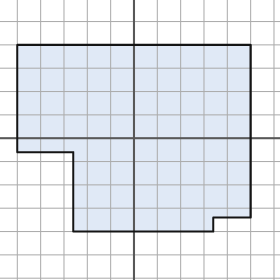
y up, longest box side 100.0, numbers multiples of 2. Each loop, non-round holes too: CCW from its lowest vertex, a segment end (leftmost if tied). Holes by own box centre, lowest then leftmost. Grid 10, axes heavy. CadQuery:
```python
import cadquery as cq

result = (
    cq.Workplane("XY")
    .moveTo(-26.0, -40.0)
    .lineTo(34.0, -40.0)
    .lineTo(34.0, -34.0)
    .lineTo(50.0, -34.0)
    .lineTo(50.0, 40.0)
    .lineTo(-50.0, 40.0)
    .lineTo(-50.0, -6.0)
    .lineTo(-26.0, -6.0)
    .close()
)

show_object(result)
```